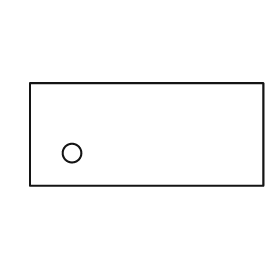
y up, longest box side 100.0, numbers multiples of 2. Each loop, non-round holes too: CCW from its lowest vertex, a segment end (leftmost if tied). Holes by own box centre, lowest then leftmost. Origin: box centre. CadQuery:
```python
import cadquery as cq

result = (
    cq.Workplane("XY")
    .moveTo(-50.0, -22.0)
    .lineTo(50.0, -22.0)
    .lineTo(50.0, 22.0)
    .lineTo(-50.0, 22.0)
    .close()
    .moveTo(-32.0, -8.0)
    .circle(4.0)
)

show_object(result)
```